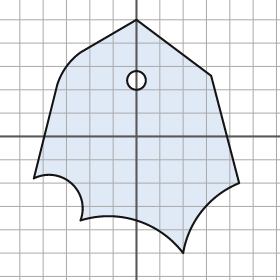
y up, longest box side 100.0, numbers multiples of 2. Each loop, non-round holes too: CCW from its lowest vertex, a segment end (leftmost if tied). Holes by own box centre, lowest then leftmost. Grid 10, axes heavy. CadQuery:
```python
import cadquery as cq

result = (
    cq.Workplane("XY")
    .moveTo(20.0, -50.0)
    .threePointArc((28.0, -32.0), (44.0, -20.0))
    .lineTo(32.0, 26.0)
    .lineTo(0.0, 50.0)
    .lineTo(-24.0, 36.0)
    .threePointArc((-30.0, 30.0), (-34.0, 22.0))
    .lineTo(-44.0, -18.0)
    .threePointArc((-28.0, -20.0), (-24.0, -36.0))
    .threePointArc((0.0, -36.0), (20.0, -50.0))
    .close()
    .moveTo(0.0, 24.0)
    .circle(4.0)
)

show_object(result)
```